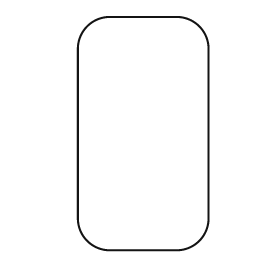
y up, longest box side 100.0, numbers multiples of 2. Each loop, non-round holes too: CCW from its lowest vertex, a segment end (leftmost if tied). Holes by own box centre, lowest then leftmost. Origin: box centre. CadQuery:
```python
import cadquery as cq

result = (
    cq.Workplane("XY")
    .moveTo(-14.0, -50.0)
    .lineTo(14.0, -50.0)
    .threePointArc((24.0, -46.0), (28.0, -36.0))
    .lineTo(28.0, 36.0)
    .threePointArc((24.0, 46.0), (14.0, 50.0))
    .lineTo(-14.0, 50.0)
    .threePointArc((-24.0, 46.0), (-28.0, 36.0))
    .lineTo(-28.0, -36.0)
    .threePointArc((-24.0, -46.0), (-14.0, -50.0))
    .close()
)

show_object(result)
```